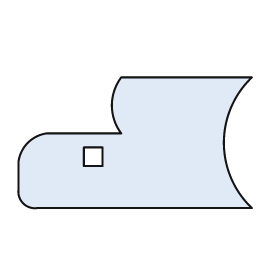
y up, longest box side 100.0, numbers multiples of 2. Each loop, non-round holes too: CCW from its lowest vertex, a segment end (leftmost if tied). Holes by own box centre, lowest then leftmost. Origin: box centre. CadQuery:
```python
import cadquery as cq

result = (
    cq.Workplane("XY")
    .moveTo(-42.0, -28.0)
    .lineTo(50.0, -28.0)
    .threePointArc((38.0, 0.0), (50.0, 28.0))
    .lineTo(-6.0, 28.0)
    .threePointArc((-10.0, 16.0), (-6.0, 4.0))
    .lineTo(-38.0, 4.0)
    .threePointArc((-46.0, 0.0), (-50.0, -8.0))
    .lineTo(-50.0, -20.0)
    .threePointArc((-48.0, -26.0), (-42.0, -28.0))
    .close()
    .moveTo(-22.0, -10.0)
    .lineTo(-14.0, -10.0)
    .lineTo(-14.0, -2.0)
    .lineTo(-22.0, -2.0)
    .close()
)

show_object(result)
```